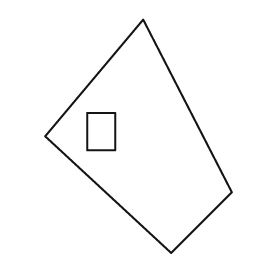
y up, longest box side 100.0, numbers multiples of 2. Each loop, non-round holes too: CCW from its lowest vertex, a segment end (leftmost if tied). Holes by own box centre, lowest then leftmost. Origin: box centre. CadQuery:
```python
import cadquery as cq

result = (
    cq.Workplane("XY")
    .moveTo(14.0, -50.0)
    .lineTo(40.0, -24.0)
    .lineTo(2.0, 50.0)
    .lineTo(-40.0, 0.0)
    .close()
    .moveTo(-22.0, -6.0)
    .lineTo(-10.0, -6.0)
    .lineTo(-10.0, 10.0)
    .lineTo(-22.0, 10.0)
    .close()
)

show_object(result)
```